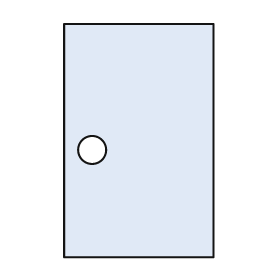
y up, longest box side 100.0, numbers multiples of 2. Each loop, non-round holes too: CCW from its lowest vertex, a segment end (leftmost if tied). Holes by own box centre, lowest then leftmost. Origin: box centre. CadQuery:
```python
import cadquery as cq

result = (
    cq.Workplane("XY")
    .moveTo(-32.0, -50.0)
    .lineTo(32.0, -50.0)
    .lineTo(32.0, 50.0)
    .lineTo(-32.0, 50.0)
    .close()
    .moveTo(-20.0, -4.0)
    .circle(6.0)
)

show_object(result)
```